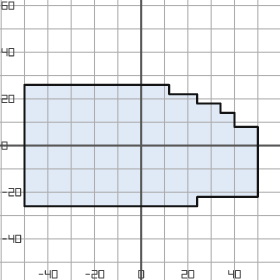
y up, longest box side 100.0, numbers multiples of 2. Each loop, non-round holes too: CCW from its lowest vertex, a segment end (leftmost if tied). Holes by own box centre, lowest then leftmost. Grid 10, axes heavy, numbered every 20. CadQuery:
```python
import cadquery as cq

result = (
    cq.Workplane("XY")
    .moveTo(-50.0, -26.0)
    .lineTo(24.0, -26.0)
    .lineTo(24.0, -22.0)
    .lineTo(50.0, -22.0)
    .lineTo(50.0, 8.0)
    .lineTo(40.0, 8.0)
    .lineTo(40.0, 14.0)
    .lineTo(34.0, 14.0)
    .lineTo(34.0, 18.0)
    .lineTo(24.0, 18.0)
    .lineTo(24.0, 22.0)
    .lineTo(12.0, 22.0)
    .lineTo(12.0, 26.0)
    .lineTo(-50.0, 26.0)
    .close()
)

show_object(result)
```